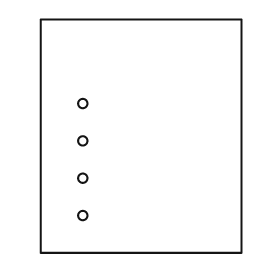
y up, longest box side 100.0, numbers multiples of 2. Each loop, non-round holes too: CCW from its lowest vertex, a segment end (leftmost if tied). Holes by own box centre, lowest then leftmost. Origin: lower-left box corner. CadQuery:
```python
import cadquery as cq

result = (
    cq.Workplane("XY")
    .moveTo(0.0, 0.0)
    .lineTo(86.0, 0.0)
    .lineTo(86.0, 100.0)
    .lineTo(0.0, 100.0)
    .close()
    .moveTo(18.0, 16.0)
    .circle(2.0)
    .moveTo(18.0, 32.0)
    .circle(2.0)
    .moveTo(18.0, 48.0)
    .circle(2.0)
    .moveTo(18.0, 64.0)
    .circle(2.0)
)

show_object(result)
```